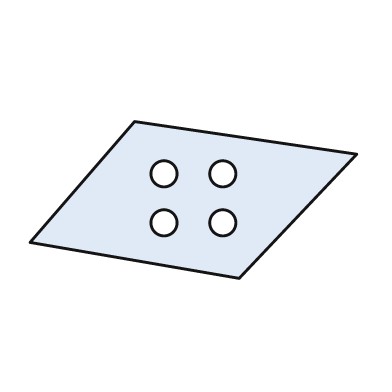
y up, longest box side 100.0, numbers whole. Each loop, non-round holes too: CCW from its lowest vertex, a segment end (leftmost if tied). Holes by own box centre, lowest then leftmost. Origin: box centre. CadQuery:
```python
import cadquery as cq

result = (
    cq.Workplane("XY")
    .moveTo(14.0, -24.0)
    .lineTo(50.0, 14.0)
    .lineTo(-18.0, 24.0)
    .lineTo(-50.0, -13.0)
    .close()
    .moveTo(-9.0, -7.0)
    .circle(4.0)
    .moveTo(9.0, -7.0)
    .circle(4.0)
    .moveTo(-9.0, 8.0)
    .circle(4.0)
    .moveTo(9.0, 8.0)
    .circle(4.0)
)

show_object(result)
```